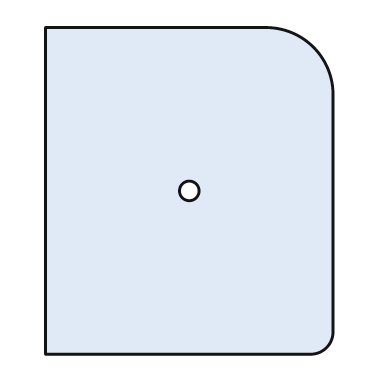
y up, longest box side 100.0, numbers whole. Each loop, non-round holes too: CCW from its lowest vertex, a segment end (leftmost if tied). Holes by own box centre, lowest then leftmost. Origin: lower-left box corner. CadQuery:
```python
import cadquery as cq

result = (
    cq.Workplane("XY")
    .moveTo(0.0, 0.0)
    .lineTo(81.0, 0.0)
    .threePointArc((86.0, 2.0), (88.0, 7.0))
    .lineTo(88.0, 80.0)
    .threePointArc((82.0, 94.0), (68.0, 100.0))
    .lineTo(0.0, 100.0)
    .close()
    .moveTo(44.0, 50.0)
    .circle(3.0)
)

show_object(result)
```